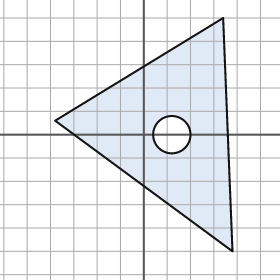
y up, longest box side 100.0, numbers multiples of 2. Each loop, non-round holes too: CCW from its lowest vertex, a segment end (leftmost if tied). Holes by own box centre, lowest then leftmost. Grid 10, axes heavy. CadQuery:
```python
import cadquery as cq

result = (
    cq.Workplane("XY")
    .moveTo(38.0, -50.0)
    .lineTo(34.0, 50.0)
    .lineTo(-38.0, 6.0)
    .close()
    .moveTo(12.0, 0.0)
    .circle(8.0)
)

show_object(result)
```